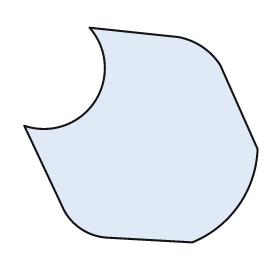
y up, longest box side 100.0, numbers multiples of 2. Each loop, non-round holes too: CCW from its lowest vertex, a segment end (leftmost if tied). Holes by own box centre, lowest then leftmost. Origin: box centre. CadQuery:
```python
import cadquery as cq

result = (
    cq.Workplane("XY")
    .moveTo(22.0, -46.0)
    .threePointArc((42.0, -30.0), (50.0, -6.0))
    .lineTo(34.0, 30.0)
    .threePointArc((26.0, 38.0), (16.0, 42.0))
    .lineTo(-22.0, 46.0)
    .threePointArc((-20.0, 14.0), (-50.0, 4.0))
    .lineTo(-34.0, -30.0)
    .threePointArc((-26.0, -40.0), (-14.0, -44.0))
    .close()
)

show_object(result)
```